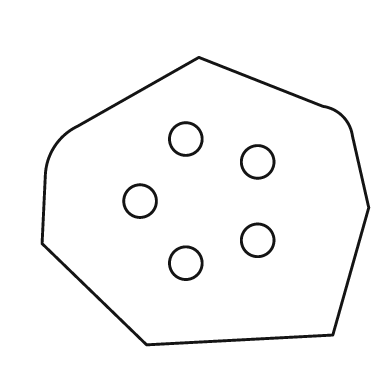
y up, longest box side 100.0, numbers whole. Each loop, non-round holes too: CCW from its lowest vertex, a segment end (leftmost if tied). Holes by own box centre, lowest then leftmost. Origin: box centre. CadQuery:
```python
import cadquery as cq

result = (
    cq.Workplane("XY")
    .moveTo(-18.0, -44.0)
    .lineTo(39.0, -41.0)
    .lineTo(50.0, -2.0)
    .lineTo(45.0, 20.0)
    .threePointArc((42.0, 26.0), (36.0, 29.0))
    .lineTo(-2.0, 44.0)
    .lineTo(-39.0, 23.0)
    .threePointArc((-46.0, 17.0), (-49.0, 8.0))
    .lineTo(-50.0, -13.0)
    .close()
    .moveTo(-6.0, -19.0)
    .circle(5.0)
    .moveTo(16.0, -12.0)
    .circle(5.0)
    .moveTo(-20.0, 0.0)
    .circle(5.0)
    .moveTo(16.0, 12.0)
    .circle(5.0)
    .moveTo(-6.0, 19.0)
    .circle(5.0)
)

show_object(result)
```